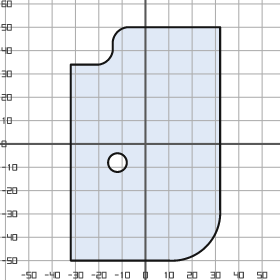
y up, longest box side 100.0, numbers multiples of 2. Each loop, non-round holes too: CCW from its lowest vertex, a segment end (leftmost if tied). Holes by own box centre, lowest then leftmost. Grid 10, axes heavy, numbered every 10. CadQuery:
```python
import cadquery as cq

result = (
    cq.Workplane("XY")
    .moveTo(-32.0, -50.0)
    .lineTo(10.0, -50.0)
    .threePointArc((26.0, -44.0), (32.0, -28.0))
    .lineTo(32.0, 50.0)
    .lineTo(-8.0, 50.0)
    .threePointArc((-12.0, 48.0), (-14.0, 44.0))
    .lineTo(-14.0, 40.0)
    .threePointArc((-16.0, 36.0), (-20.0, 34.0))
    .lineTo(-32.0, 34.0)
    .close()
    .moveTo(-12.0, -8.0)
    .circle(4.0)
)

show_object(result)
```